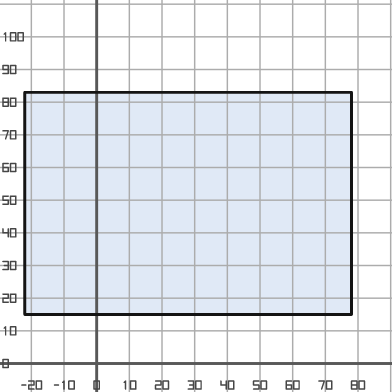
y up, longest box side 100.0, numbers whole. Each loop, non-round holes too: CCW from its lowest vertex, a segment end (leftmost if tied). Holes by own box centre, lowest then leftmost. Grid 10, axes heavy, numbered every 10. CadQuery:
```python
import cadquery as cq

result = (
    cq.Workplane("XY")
    .moveTo(-22.0, 15.0)
    .lineTo(78.0, 15.0)
    .lineTo(78.0, 83.0)
    .lineTo(-22.0, 83.0)
    .close()
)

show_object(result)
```